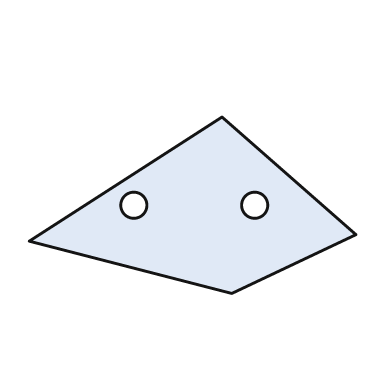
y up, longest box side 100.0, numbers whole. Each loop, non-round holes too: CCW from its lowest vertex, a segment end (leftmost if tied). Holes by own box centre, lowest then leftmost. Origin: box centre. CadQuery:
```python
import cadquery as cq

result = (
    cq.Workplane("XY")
    .moveTo(12.0, -27.0)
    .lineTo(50.0, -9.0)
    .lineTo(9.0, 27.0)
    .lineTo(-50.0, -11.0)
    .close()
    .moveTo(-18.0, 0.0)
    .circle(4.0)
    .moveTo(19.0, 0.0)
    .circle(4.0)
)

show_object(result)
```